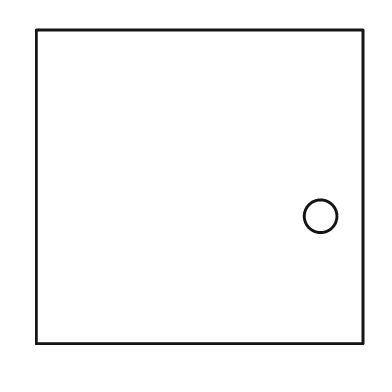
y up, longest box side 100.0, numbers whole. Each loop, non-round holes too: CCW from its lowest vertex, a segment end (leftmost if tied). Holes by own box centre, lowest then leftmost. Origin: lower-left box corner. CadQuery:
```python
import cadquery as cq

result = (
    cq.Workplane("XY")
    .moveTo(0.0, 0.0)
    .lineTo(100.0, 0.0)
    .lineTo(100.0, 96.0)
    .lineTo(0.0, 96.0)
    .close()
    .moveTo(87.0, 39.0)
    .circle(5.0)
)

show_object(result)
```